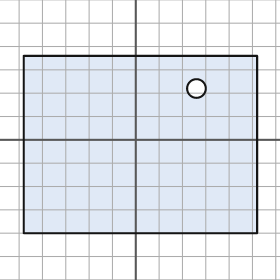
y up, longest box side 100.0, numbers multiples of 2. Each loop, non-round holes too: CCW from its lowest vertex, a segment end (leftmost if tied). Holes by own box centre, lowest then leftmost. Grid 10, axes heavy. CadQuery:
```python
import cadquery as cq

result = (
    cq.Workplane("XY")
    .moveTo(-48.0, -40.0)
    .lineTo(52.0, -40.0)
    .lineTo(52.0, 36.0)
    .lineTo(-48.0, 36.0)
    .close()
    .moveTo(26.0, 22.0)
    .circle(4.0)
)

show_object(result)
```